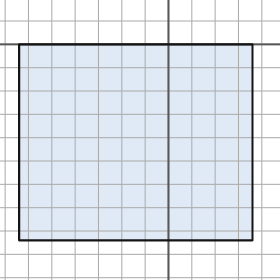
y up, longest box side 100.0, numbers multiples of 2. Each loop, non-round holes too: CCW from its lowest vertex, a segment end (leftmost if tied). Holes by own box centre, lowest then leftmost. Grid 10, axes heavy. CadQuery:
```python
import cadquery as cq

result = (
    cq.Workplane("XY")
    .moveTo(-64.0, -84.0)
    .lineTo(36.0, -84.0)
    .lineTo(36.0, 0.0)
    .lineTo(-64.0, 0.0)
    .close()
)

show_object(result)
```